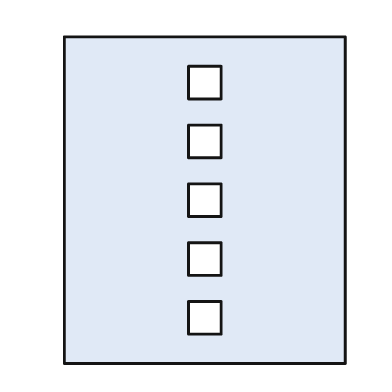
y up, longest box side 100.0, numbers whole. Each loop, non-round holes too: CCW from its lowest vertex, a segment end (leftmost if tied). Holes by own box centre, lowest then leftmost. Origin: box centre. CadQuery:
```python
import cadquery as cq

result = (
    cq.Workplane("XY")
    .moveTo(-43.0, -50.0)
    .lineTo(43.0, -50.0)
    .lineTo(43.0, 50.0)
    .lineTo(-43.0, 50.0)
    .close()
    .moveTo(-5.0, -41.0)
    .lineTo(5.0, -41.0)
    .lineTo(5.0, -31.0)
    .lineTo(-5.0, -31.0)
    .close()
    .moveTo(-5.0, -23.0)
    .lineTo(5.0, -23.0)
    .lineTo(5.0, -13.0)
    .lineTo(-5.0, -13.0)
    .close()
    .moveTo(-5.0, -5.0)
    .lineTo(5.0, -5.0)
    .lineTo(5.0, 5.0)
    .lineTo(-5.0, 5.0)
    .close()
    .moveTo(-5.0, 13.0)
    .lineTo(5.0, 13.0)
    .lineTo(5.0, 23.0)
    .lineTo(-5.0, 23.0)
    .close()
    .moveTo(-5.0, 31.0)
    .lineTo(5.0, 31.0)
    .lineTo(5.0, 41.0)
    .lineTo(-5.0, 41.0)
    .close()
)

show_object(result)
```